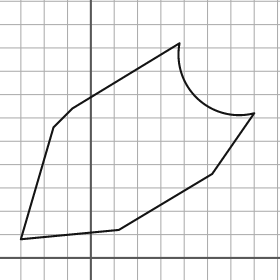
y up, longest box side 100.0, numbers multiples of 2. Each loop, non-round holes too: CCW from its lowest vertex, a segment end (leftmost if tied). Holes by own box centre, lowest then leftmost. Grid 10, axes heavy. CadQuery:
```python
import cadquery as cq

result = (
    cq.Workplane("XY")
    .moveTo(-30.0, 8.0)
    .lineTo(12.0, 12.0)
    .lineTo(52.0, 36.0)
    .lineTo(70.0, 62.0)
    .threePointArc((46.0, 68.0), (38.0, 92.0))
    .lineTo(-8.0, 64.0)
    .lineTo(-16.0, 56.0)
    .close()
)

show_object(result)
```